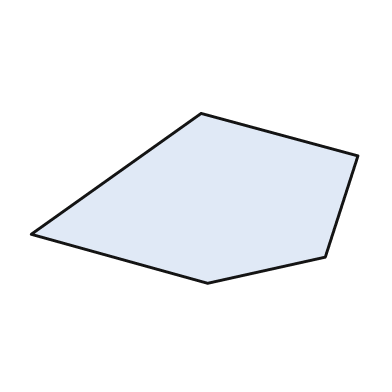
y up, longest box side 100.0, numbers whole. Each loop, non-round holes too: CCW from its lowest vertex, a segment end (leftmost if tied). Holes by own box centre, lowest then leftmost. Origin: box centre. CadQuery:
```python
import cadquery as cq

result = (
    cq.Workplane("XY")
    .moveTo(4.0, -26.0)
    .lineTo(40.0, -18.0)
    .lineTo(50.0, 13.0)
    .lineTo(2.0, 26.0)
    .lineTo(-50.0, -11.0)
    .close()
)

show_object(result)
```